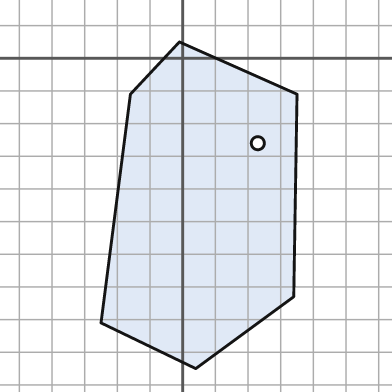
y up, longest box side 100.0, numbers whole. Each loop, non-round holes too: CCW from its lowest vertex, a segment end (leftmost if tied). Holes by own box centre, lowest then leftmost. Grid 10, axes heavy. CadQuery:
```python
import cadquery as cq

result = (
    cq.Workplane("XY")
    .moveTo(4.0, -95.0)
    .lineTo(34.0, -73.0)
    .lineTo(35.0, -11.0)
    .lineTo(-1.0, 5.0)
    .lineTo(-16.0, -11.0)
    .lineTo(-25.0, -81.0)
    .close()
    .moveTo(23.0, -26.0)
    .circle(2.0)
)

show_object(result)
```